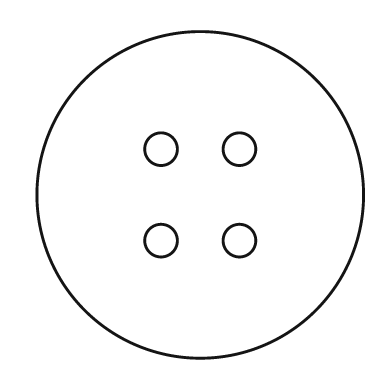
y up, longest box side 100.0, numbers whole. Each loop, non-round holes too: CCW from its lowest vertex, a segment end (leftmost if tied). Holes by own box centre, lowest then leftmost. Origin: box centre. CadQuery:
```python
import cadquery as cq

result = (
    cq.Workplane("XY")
    .moveTo(0.0, 0.0)
    .circle(50.0)
    .moveTo(-12.0, -14.0)
    .circle(5.0)
    .moveTo(12.0, -14.0)
    .circle(5.0)
    .moveTo(-12.0, 14.0)
    .circle(5.0)
    .moveTo(12.0, 14.0)
    .circle(5.0)
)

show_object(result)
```